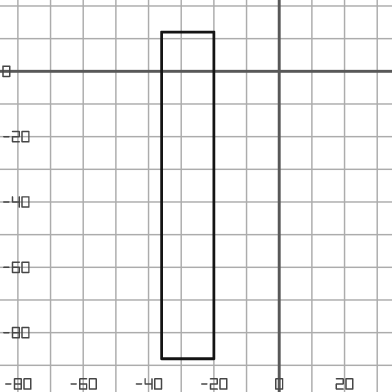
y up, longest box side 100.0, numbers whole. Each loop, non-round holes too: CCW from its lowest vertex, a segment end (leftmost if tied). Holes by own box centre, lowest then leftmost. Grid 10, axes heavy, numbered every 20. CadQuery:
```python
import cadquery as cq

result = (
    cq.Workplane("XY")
    .moveTo(-36.0, -88.0)
    .lineTo(-20.0, -88.0)
    .lineTo(-20.0, 12.0)
    .lineTo(-36.0, 12.0)
    .close()
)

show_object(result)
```